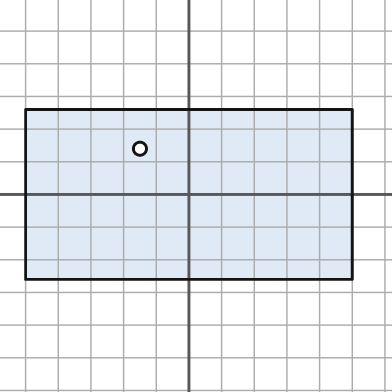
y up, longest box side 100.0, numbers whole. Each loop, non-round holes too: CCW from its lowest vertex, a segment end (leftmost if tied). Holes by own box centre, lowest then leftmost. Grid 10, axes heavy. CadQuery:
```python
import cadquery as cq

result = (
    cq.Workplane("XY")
    .moveTo(-50.0, -26.0)
    .lineTo(50.0, -26.0)
    .lineTo(50.0, 26.0)
    .lineTo(-50.0, 26.0)
    .close()
    .moveTo(-15.0, 14.0)
    .circle(2.0)
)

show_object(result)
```